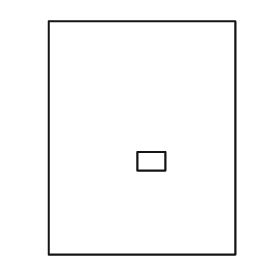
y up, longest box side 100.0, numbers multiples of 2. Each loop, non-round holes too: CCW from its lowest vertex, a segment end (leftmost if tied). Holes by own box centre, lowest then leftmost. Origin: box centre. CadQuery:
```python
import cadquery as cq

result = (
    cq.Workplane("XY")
    .moveTo(-40.0, -50.0)
    .lineTo(40.0, -50.0)
    .lineTo(40.0, 50.0)
    .lineTo(-40.0, 50.0)
    .close()
    .moveTo(-2.0, -14.0)
    .lineTo(10.0, -14.0)
    .lineTo(10.0, -6.0)
    .lineTo(-2.0, -6.0)
    .close()
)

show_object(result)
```